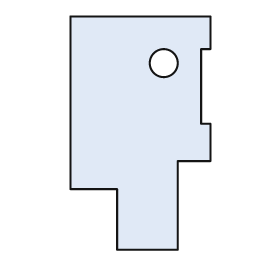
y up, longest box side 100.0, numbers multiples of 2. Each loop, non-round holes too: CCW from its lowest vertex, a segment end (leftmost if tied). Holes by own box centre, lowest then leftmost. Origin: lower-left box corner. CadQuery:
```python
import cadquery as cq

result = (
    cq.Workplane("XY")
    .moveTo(20.0, 0.0)
    .lineTo(46.0, 0.0)
    .lineTo(46.0, 38.0)
    .lineTo(60.0, 38.0)
    .lineTo(60.0, 54.0)
    .lineTo(56.0, 54.0)
    .lineTo(56.0, 86.0)
    .lineTo(60.0, 86.0)
    .lineTo(60.0, 100.0)
    .lineTo(0.0, 100.0)
    .lineTo(0.0, 26.0)
    .lineTo(20.0, 26.0)
    .close()
    .moveTo(40.0, 80.0)
    .circle(6.0)
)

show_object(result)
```